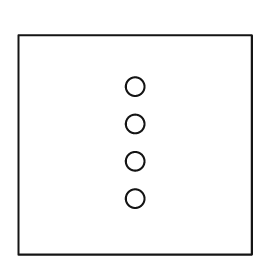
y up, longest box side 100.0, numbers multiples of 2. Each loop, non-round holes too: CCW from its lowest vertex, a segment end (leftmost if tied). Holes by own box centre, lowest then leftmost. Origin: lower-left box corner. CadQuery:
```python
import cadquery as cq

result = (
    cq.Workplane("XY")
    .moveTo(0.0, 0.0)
    .lineTo(100.0, 0.0)
    .lineTo(100.0, 94.0)
    .lineTo(0.0, 94.0)
    .close()
    .moveTo(50.0, 24.0)
    .circle(4.0)
    .moveTo(50.0, 40.0)
    .circle(4.0)
    .moveTo(50.0, 56.0)
    .circle(4.0)
    .moveTo(50.0, 72.0)
    .circle(4.0)
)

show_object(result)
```